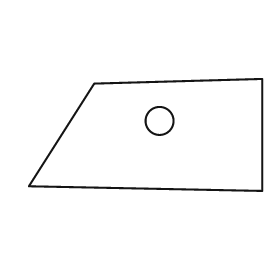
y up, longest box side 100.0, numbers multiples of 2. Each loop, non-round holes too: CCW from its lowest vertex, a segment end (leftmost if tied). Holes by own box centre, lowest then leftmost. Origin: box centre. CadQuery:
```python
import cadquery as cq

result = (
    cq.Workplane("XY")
    .moveTo(50.0, -24.0)
    .lineTo(50.0, 24.0)
    .lineTo(-22.0, 22.0)
    .lineTo(-50.0, -22.0)
    .close()
    .moveTo(6.0, 6.0)
    .circle(6.0)
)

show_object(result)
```